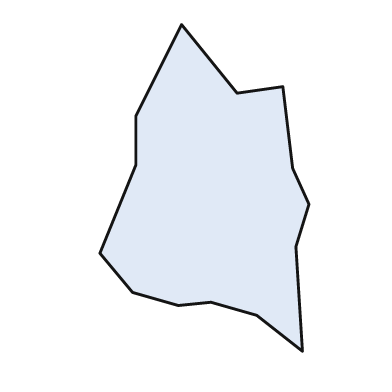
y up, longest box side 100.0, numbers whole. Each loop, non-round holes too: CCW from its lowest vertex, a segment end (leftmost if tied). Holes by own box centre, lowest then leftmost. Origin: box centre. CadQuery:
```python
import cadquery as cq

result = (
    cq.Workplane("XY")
    .moveTo(30.0, -50.0)
    .lineTo(28.0, -18.0)
    .lineTo(32.0, -5.0)
    .lineTo(27.0, 6.0)
    .lineTo(24.0, 31.0)
    .lineTo(10.0, 29.0)
    .lineTo(-7.0, 50.0)
    .lineTo(-21.0, 22.0)
    .lineTo(-21.0, 7.0)
    .lineTo(-32.0, -20.0)
    .lineTo(-22.0, -32.0)
    .lineTo(-8.0, -36.0)
    .lineTo(2.0, -35.0)
    .lineTo(16.0, -39.0)
    .close()
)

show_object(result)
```